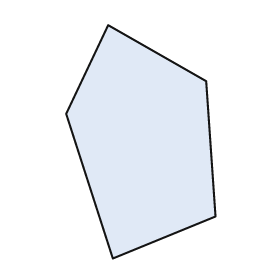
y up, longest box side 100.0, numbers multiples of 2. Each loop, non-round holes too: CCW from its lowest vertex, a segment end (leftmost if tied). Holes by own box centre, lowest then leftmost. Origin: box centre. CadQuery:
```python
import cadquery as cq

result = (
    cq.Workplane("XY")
    .moveTo(-12.0, -50.0)
    .lineTo(32.0, -32.0)
    .lineTo(28.0, 26.0)
    .lineTo(-14.0, 50.0)
    .lineTo(-32.0, 12.0)
    .close()
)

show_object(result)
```